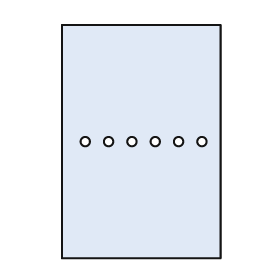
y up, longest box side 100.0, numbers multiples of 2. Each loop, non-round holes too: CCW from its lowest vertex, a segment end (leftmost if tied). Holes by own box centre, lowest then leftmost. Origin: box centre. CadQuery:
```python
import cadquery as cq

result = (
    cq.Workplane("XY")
    .moveTo(-34.0, -50.0)
    .lineTo(34.0, -50.0)
    .lineTo(34.0, 50.0)
    .lineTo(-34.0, 50.0)
    .close()
    .moveTo(-24.0, 0.0)
    .circle(2.0)
    .moveTo(-14.0, 0.0)
    .circle(2.0)
    .moveTo(-4.0, 0.0)
    .circle(2.0)
    .moveTo(6.0, 0.0)
    .circle(2.0)
    .moveTo(16.0, 0.0)
    .circle(2.0)
    .moveTo(26.0, 0.0)
    .circle(2.0)
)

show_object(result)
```